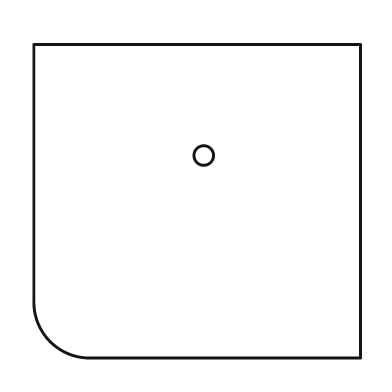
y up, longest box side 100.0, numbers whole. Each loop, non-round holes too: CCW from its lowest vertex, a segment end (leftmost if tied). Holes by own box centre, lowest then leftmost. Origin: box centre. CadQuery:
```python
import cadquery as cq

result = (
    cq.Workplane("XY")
    .moveTo(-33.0, -48.0)
    .lineTo(50.0, -48.0)
    .lineTo(50.0, 48.0)
    .lineTo(-50.0, 48.0)
    .lineTo(-50.0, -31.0)
    .threePointArc((-45.0, -43.0), (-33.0, -48.0))
    .close()
    .moveTo(2.0, 14.0)
    .circle(3.0)
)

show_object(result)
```